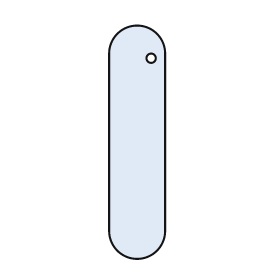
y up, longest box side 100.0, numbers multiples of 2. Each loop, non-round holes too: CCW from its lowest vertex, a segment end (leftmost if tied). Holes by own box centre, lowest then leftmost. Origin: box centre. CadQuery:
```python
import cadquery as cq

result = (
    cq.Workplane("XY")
    .moveTo(-12.0, -38.0)
    .threePointArc((0.0, -50.0), (12.0, -38.0))
    .lineTo(12.0, 38.0)
    .threePointArc((0.0, 50.0), (-12.0, 38.0))
    .close()
    .moveTo(6.0, 36.0)
    .circle(2.0)
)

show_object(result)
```